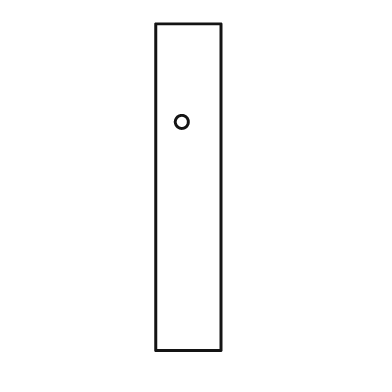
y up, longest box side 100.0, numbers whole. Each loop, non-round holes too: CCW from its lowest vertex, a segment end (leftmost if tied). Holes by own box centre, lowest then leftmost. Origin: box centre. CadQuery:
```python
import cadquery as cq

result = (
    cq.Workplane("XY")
    .moveTo(-10.0, -50.0)
    .lineTo(10.0, -50.0)
    .lineTo(10.0, 50.0)
    .lineTo(-10.0, 50.0)
    .close()
    .moveTo(-2.0, 20.0)
    .circle(2.0)
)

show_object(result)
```